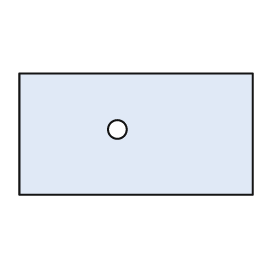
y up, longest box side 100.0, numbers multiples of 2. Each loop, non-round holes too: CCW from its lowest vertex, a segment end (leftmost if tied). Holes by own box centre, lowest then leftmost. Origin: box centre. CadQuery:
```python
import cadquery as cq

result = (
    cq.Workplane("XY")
    .moveTo(-50.0, -26.0)
    .lineTo(50.0, -26.0)
    .lineTo(50.0, 26.0)
    .lineTo(-50.0, 26.0)
    .close()
    .moveTo(-8.0, 2.0)
    .circle(4.0)
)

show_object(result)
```